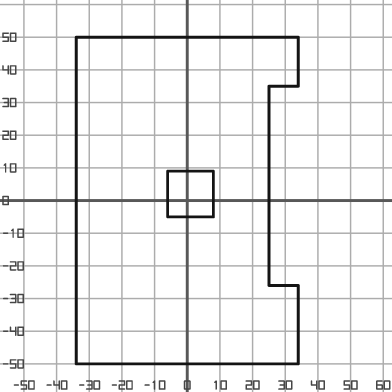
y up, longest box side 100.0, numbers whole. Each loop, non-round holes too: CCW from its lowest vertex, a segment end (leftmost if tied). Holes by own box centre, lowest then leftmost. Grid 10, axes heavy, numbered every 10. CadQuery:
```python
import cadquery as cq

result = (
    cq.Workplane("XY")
    .moveTo(-34.0, -50.0)
    .lineTo(34.0, -50.0)
    .lineTo(34.0, -26.0)
    .lineTo(25.0, -26.0)
    .lineTo(25.0, 35.0)
    .lineTo(34.0, 35.0)
    .lineTo(34.0, 50.0)
    .lineTo(-34.0, 50.0)
    .close()
    .moveTo(-6.0, -5.0)
    .lineTo(8.0, -5.0)
    .lineTo(8.0, 9.0)
    .lineTo(-6.0, 9.0)
    .close()
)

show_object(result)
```